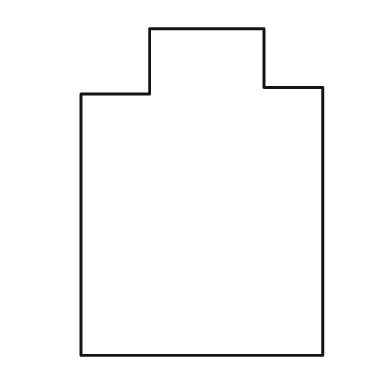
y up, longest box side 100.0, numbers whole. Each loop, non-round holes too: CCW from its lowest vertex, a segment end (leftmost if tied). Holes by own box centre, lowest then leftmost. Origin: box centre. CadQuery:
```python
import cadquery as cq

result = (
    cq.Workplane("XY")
    .moveTo(-37.0, -50.0)
    .lineTo(37.0, -50.0)
    .lineTo(37.0, 32.0)
    .lineTo(19.0, 32.0)
    .lineTo(19.0, 50.0)
    .lineTo(-16.0, 50.0)
    .lineTo(-16.0, 30.0)
    .lineTo(-37.0, 30.0)
    .close()
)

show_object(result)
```